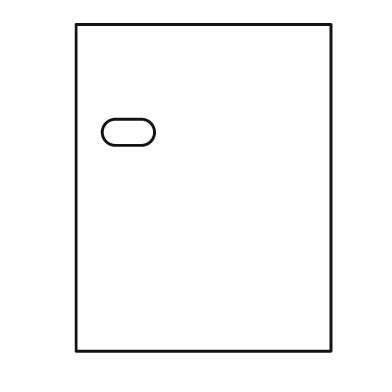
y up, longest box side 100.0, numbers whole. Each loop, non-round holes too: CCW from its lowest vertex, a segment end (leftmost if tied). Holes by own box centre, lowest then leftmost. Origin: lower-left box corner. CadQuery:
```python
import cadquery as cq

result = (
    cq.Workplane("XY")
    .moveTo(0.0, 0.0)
    .lineTo(78.0, 0.0)
    .lineTo(78.0, 100.0)
    .lineTo(0.0, 100.0)
    .close()
    .moveTo(12.0, 63.0)
    .lineTo(20.0, 63.0)
    .threePointArc((24.0, 67.0), (20.0, 71.0))
    .lineTo(12.0, 71.0)
    .threePointArc((8.0, 67.0), (12.0, 63.0))
    .close()
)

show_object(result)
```